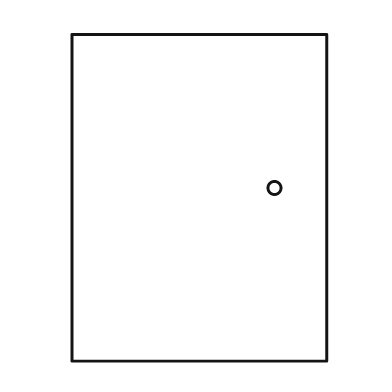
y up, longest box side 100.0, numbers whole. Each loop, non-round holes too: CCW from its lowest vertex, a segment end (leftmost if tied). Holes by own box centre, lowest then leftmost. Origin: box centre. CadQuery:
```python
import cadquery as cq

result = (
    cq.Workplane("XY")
    .moveTo(-39.0, -50.0)
    .lineTo(39.0, -50.0)
    .lineTo(39.0, 50.0)
    .lineTo(-39.0, 50.0)
    .close()
    .moveTo(23.0, 3.0)
    .circle(2.0)
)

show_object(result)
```